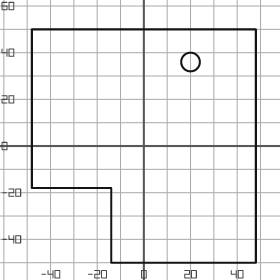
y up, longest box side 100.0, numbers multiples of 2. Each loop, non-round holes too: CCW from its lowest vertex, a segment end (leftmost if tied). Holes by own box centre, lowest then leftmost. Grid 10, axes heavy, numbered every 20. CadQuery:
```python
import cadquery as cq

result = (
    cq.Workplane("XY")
    .moveTo(-14.0, -50.0)
    .lineTo(48.0, -50.0)
    .lineTo(48.0, 50.0)
    .lineTo(-48.0, 50.0)
    .lineTo(-48.0, -18.0)
    .lineTo(-14.0, -18.0)
    .close()
    .moveTo(20.0, 36.0)
    .circle(4.0)
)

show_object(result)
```